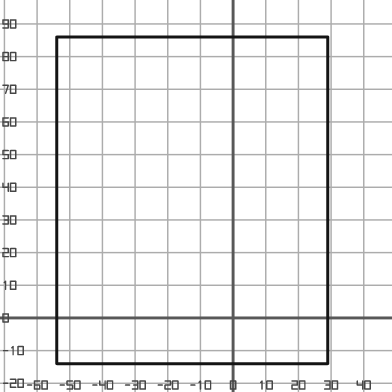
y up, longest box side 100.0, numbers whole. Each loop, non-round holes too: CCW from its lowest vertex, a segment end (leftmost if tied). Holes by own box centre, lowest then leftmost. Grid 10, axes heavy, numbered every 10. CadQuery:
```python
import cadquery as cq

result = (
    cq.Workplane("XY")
    .moveTo(-54.0, -14.0)
    .lineTo(29.0, -14.0)
    .lineTo(29.0, 86.0)
    .lineTo(-54.0, 86.0)
    .close()
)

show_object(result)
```